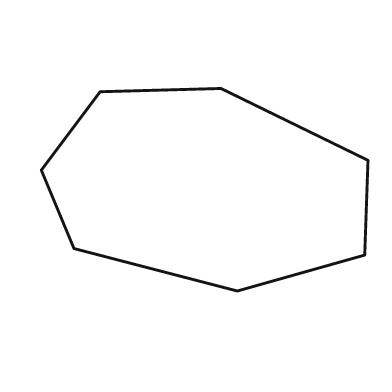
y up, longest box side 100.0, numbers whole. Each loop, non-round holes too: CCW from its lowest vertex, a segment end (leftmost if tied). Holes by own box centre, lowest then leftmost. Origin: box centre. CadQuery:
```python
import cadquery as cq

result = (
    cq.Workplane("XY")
    .moveTo(10.0, -31.0)
    .lineTo(49.0, -20.0)
    .lineTo(50.0, 9.0)
    .lineTo(5.0, 31.0)
    .lineTo(-32.0, 30.0)
    .lineTo(-50.0, 6.0)
    .lineTo(-40.0, -18.0)
    .close()
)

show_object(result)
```